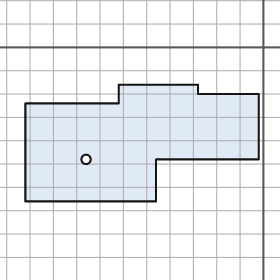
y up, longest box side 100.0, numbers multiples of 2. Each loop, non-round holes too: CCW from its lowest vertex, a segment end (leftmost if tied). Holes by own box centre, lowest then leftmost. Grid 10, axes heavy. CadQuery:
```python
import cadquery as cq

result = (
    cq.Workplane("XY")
    .moveTo(-102.0, -66.0)
    .lineTo(-46.0, -66.0)
    .lineTo(-46.0, -48.0)
    .lineTo(-2.0, -48.0)
    .lineTo(-2.0, -20.0)
    .lineTo(-28.0, -20.0)
    .lineTo(-28.0, -16.0)
    .lineTo(-62.0, -16.0)
    .lineTo(-62.0, -24.0)
    .lineTo(-102.0, -24.0)
    .close()
    .moveTo(-76.0, -48.0)
    .circle(2.0)
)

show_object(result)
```